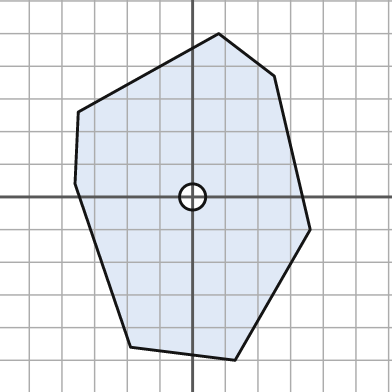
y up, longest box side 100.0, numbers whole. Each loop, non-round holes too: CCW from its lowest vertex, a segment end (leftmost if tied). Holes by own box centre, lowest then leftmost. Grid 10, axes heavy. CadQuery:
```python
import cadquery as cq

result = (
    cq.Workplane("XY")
    .moveTo(13.0, -50.0)
    .lineTo(36.0, -10.0)
    .lineTo(25.0, 37.0)
    .lineTo(8.0, 50.0)
    .lineTo(-35.0, 26.0)
    .lineTo(-36.0, 4.0)
    .lineTo(-19.0, -46.0)
    .close()
    .moveTo(0.0, 0.0)
    .circle(4.0)
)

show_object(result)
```